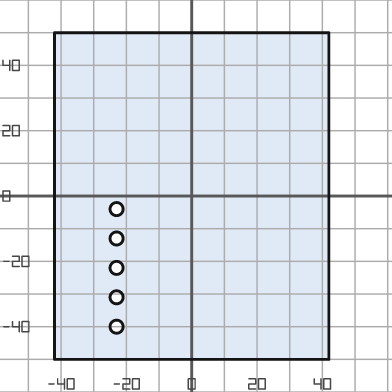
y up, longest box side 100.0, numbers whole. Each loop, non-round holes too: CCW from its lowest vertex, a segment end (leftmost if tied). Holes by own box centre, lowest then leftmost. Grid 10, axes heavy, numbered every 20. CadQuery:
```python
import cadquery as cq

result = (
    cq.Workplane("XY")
    .moveTo(-42.0, -50.0)
    .lineTo(42.0, -50.0)
    .lineTo(42.0, 50.0)
    .lineTo(-42.0, 50.0)
    .close()
    .moveTo(-23.0, -40.0)
    .circle(2.0)
    .moveTo(-23.0, -31.0)
    .circle(2.0)
    .moveTo(-23.0, -22.0)
    .circle(2.0)
    .moveTo(-23.0, -13.0)
    .circle(2.0)
    .moveTo(-23.0, -4.0)
    .circle(2.0)
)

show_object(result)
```